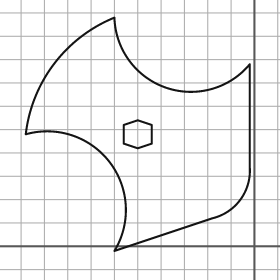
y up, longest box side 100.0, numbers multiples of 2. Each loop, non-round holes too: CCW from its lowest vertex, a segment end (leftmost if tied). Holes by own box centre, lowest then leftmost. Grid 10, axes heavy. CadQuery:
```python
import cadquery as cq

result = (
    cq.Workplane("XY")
    .moveTo(-60.0, -2.0)
    .lineTo(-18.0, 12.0)
    .threePointArc((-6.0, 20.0), (-2.0, 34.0))
    .lineTo(-2.0, 78.0)
    .threePointArc((-38.0, 68.0), (-60.0, 98.0))
    .threePointArc((-86.0, 78.0), (-98.0, 48.0))
    .threePointArc((-62.0, 36.0), (-60.0, -2.0))
    .close()
    .moveTo(-50.0, 42.0)
    .lineTo(-44.0, 44.0)
    .lineTo(-44.0, 52.0)
    .lineTo(-50.0, 54.0)
    .lineTo(-56.0, 52.0)
    .lineTo(-56.0, 44.0)
    .close()
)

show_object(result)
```